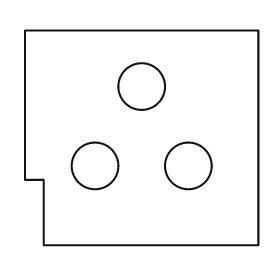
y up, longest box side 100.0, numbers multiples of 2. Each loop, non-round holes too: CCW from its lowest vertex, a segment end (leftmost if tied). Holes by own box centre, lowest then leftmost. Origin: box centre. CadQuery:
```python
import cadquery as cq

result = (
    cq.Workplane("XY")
    .moveTo(-42.0, -46.0)
    .lineTo(50.0, -46.0)
    .lineTo(50.0, 46.0)
    .lineTo(-50.0, 46.0)
    .lineTo(-50.0, -18.0)
    .lineTo(-42.0, -18.0)
    .close()
    .moveTo(-20.0, -12.0)
    .circle(10.0)
    .moveTo(20.0, -12.0)
    .circle(10.0)
    .moveTo(0.0, 22.0)
    .circle(10.0)
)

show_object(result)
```